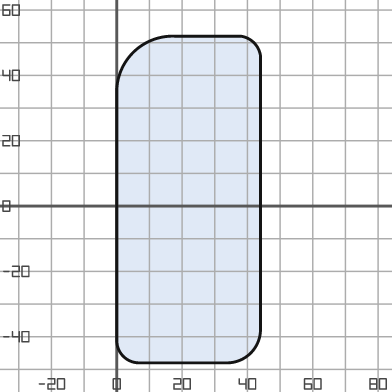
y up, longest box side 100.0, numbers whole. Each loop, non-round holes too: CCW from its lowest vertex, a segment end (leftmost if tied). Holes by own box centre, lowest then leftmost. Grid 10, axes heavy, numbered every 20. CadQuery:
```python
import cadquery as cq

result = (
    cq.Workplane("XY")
    .moveTo(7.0, -48.0)
    .lineTo(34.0, -48.0)
    .threePointArc((41.0, -45.0), (44.0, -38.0))
    .lineTo(44.0, 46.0)
    .threePointArc((42.0, 50.0), (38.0, 52.0))
    .lineTo(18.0, 52.0)
    .threePointArc((5.0, 47.0), (0.0, 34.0))
    .lineTo(0.0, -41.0)
    .threePointArc((2.0, -46.0), (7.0, -48.0))
    .close()
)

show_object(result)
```